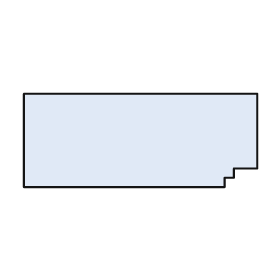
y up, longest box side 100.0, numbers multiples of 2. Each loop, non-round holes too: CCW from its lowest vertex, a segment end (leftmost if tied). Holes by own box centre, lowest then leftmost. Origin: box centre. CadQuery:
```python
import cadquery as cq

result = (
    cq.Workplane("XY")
    .moveTo(-50.0, -20.0)
    .lineTo(36.0, -20.0)
    .lineTo(36.0, -16.0)
    .lineTo(40.0, -16.0)
    .lineTo(40.0, -12.0)
    .lineTo(50.0, -12.0)
    .lineTo(50.0, 20.0)
    .lineTo(-50.0, 20.0)
    .close()
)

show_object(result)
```